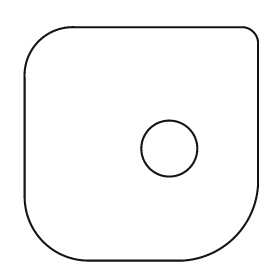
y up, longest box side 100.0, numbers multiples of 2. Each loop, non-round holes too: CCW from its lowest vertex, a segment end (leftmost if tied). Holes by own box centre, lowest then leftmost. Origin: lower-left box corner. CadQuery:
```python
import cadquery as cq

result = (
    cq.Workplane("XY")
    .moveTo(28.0, 0.0)
    .lineTo(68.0, 0.0)
    .threePointArc((90.0, 10.0), (100.0, 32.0))
    .lineTo(100.0, 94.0)
    .threePointArc((98.0, 98.0), (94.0, 100.0))
    .lineTo(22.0, 100.0)
    .threePointArc((6.0, 94.0), (0.0, 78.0))
    .lineTo(0.0, 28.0)
    .threePointArc((8.0, 8.0), (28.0, 0.0))
    .close()
    .moveTo(62.0, 48.0)
    .circle(12.0)
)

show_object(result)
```